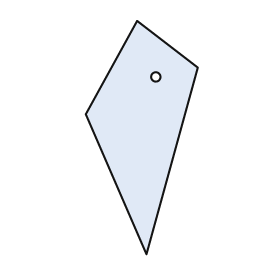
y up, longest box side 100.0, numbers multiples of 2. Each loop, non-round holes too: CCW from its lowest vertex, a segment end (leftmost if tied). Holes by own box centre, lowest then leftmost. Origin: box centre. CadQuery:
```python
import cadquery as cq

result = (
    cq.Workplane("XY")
    .moveTo(2.0, -50.0)
    .lineTo(24.0, 30.0)
    .lineTo(-2.0, 50.0)
    .lineTo(-24.0, 10.0)
    .close()
    .moveTo(6.0, 26.0)
    .circle(2.0)
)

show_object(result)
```